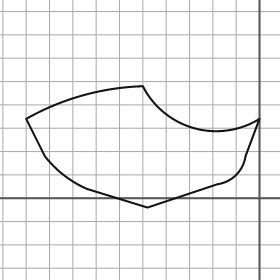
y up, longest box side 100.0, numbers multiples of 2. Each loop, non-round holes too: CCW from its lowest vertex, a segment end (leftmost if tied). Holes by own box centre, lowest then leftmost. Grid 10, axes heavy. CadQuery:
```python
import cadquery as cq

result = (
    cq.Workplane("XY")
    .moveTo(-48.0, -4.0)
    .lineTo(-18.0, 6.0)
    .threePointArc((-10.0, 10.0), (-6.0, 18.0))
    .lineTo(0.0, 34.0)
    .threePointArc((-28.0, 30.0), (-50.0, 48.0))
    .threePointArc((-76.0, 44.0), (-100.0, 34.0))
    .lineTo(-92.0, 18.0)
    .threePointArc((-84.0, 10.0), (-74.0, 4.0))
    .close()
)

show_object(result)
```